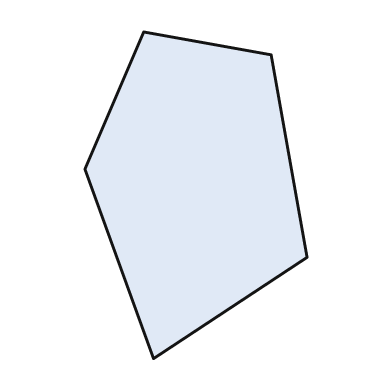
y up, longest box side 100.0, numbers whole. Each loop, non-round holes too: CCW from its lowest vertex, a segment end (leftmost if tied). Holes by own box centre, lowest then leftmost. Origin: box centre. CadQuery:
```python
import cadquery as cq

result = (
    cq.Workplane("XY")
    .moveTo(-13.0, -50.0)
    .lineTo(34.0, -19.0)
    .lineTo(23.0, 43.0)
    .lineTo(-16.0, 50.0)
    .lineTo(-34.0, 8.0)
    .close()
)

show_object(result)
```